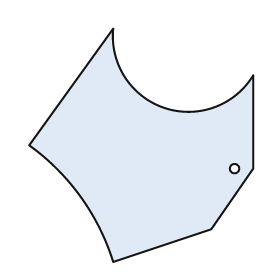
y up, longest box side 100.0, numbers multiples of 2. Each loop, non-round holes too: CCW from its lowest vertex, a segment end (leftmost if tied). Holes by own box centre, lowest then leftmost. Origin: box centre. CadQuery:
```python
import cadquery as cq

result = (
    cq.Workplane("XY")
    .moveTo(-12.0, -50.0)
    .lineTo(30.0, -36.0)
    .lineTo(48.0, -10.0)
    .lineTo(48.0, 30.0)
    .threePointArc((10.0, 16.0), (-12.0, 50.0))
    .lineTo(-48.0, 0.0)
    .threePointArc((-26.0, -22.0), (-12.0, -50.0))
    .close()
    .moveTo(40.0, -10.0)
    .circle(2.0)
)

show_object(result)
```